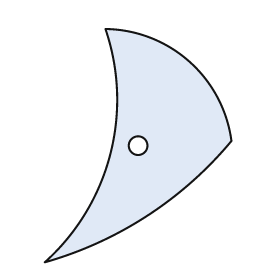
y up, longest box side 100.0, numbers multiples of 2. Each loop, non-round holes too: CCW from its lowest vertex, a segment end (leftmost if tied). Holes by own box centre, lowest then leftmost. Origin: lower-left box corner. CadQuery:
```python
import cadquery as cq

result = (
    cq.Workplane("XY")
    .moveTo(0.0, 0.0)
    .threePointArc((44.0, 20.0), (80.0, 52.0))
    .threePointArc((62.0, 86.0), (26.0, 100.0))
    .threePointArc((28.0, 46.0), (0.0, 0.0))
    .close()
    .moveTo(40.0, 50.0)
    .circle(4.0)
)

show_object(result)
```